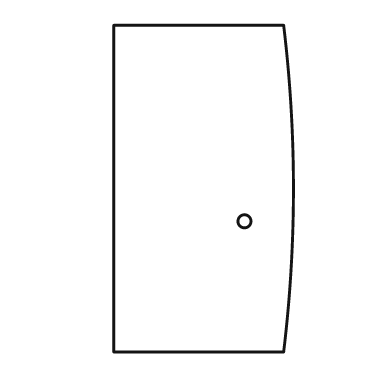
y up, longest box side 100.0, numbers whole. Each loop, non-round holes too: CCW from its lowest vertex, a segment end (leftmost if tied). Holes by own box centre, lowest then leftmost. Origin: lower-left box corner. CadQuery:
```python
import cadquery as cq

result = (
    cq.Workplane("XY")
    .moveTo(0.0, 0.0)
    .lineTo(52.0, 0.0)
    .threePointArc((55.0, 50.0), (52.0, 100.0))
    .lineTo(0.0, 100.0)
    .close()
    .moveTo(40.0, 40.0)
    .circle(2.0)
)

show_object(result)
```